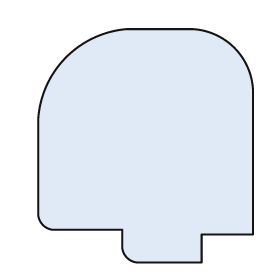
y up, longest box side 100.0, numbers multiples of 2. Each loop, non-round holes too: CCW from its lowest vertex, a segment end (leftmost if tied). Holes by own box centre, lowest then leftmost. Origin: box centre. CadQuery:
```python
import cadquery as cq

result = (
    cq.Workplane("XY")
    .moveTo(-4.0, -50.0)
    .lineTo(24.0, -50.0)
    .lineTo(24.0, -38.0)
    .lineTo(46.0, -38.0)
    .lineTo(46.0, 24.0)
    .threePointArc((38.0, 42.0), (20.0, 50.0))
    .lineTo(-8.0, 50.0)
    .threePointArc((-34.0, 38.0), (-46.0, 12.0))
    .lineTo(-46.0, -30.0)
    .threePointArc((-44.0, -34.0), (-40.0, -36.0))
    .lineTo(-10.0, -36.0)
    .lineTo(-10.0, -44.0)
    .threePointArc((-8.0, -48.0), (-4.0, -50.0))
    .close()
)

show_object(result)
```